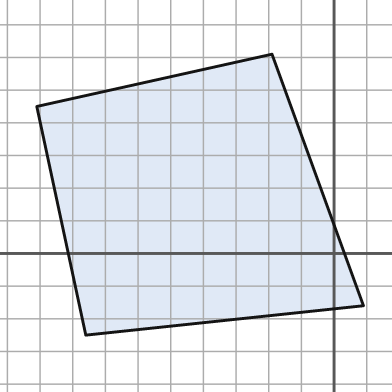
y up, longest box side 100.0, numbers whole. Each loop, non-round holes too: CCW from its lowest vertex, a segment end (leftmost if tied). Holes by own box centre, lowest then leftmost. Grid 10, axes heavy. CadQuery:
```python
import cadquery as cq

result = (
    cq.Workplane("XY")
    .moveTo(-76.0, -25.0)
    .lineTo(9.0, -16.0)
    .lineTo(-19.0, 61.0)
    .lineTo(-91.0, 45.0)
    .close()
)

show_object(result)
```